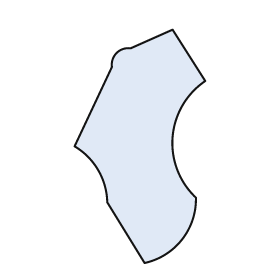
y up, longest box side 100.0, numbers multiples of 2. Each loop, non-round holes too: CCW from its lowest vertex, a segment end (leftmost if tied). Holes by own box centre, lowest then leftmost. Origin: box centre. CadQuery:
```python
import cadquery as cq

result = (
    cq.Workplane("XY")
    .moveTo(2.0, -50.0)
    .threePointArc((18.0, -40.0), (24.0, -22.0))
    .threePointArc((14.0, 4.0), (28.0, 28.0))
    .lineTo(14.0, 50.0)
    .lineTo(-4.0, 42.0)
    .threePointArc((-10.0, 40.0), (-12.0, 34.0))
    .lineTo(-28.0, 0.0)
    .threePointArc((-18.0, -10.0), (-14.0, -24.0))
    .close()
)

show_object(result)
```